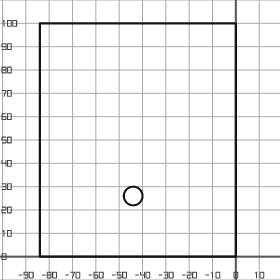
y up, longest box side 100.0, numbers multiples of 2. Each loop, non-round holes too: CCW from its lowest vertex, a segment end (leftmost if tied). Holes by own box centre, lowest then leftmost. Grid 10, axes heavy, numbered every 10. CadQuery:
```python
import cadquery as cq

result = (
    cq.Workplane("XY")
    .moveTo(-84.0, 0.0)
    .lineTo(0.0, 0.0)
    .lineTo(0.0, 100.0)
    .lineTo(-84.0, 100.0)
    .close()
    .moveTo(-44.0, 26.0)
    .circle(4.0)
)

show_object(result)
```